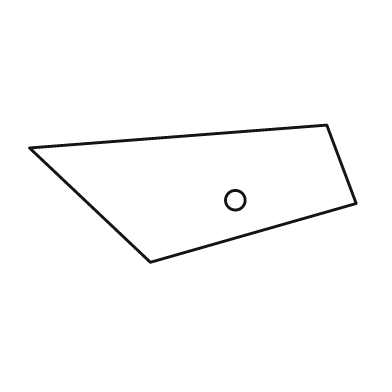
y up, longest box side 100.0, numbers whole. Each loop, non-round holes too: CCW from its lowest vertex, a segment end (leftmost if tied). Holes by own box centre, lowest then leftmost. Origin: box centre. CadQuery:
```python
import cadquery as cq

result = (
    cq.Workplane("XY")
    .moveTo(-13.0, -21.0)
    .lineTo(50.0, -3.0)
    .lineTo(41.0, 21.0)
    .lineTo(-50.0, 14.0)
    .close()
    .moveTo(13.0, -2.0)
    .circle(3.0)
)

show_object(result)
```